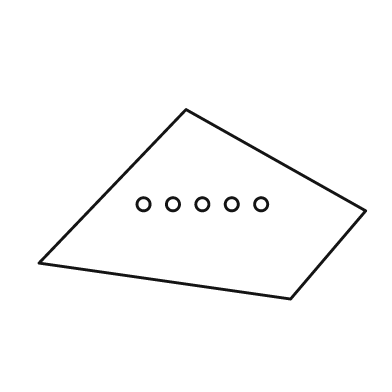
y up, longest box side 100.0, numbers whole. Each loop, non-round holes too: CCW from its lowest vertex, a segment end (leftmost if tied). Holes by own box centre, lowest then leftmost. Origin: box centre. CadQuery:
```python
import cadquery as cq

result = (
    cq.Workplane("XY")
    .moveTo(27.0, -29.0)
    .lineTo(50.0, -2.0)
    .lineTo(-5.0, 29.0)
    .lineTo(-50.0, -18.0)
    .close()
    .moveTo(-18.0, 0.0)
    .circle(2.0)
    .moveTo(-9.0, 0.0)
    .circle(2.0)
    .moveTo(0.0, 0.0)
    .circle(2.0)
    .moveTo(9.0, 0.0)
    .circle(2.0)
    .moveTo(18.0, 0.0)
    .circle(2.0)
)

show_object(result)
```